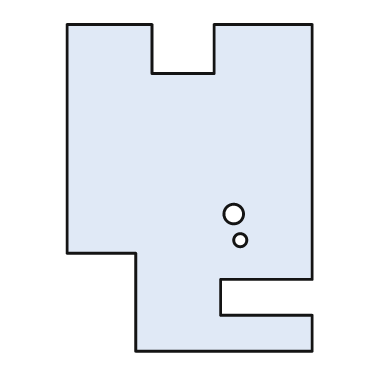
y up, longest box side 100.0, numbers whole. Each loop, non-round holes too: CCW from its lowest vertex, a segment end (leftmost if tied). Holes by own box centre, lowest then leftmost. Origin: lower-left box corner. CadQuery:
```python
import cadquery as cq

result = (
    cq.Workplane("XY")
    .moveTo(21.0, 0.0)
    .lineTo(75.0, 0.0)
    .lineTo(75.0, 11.0)
    .lineTo(47.0, 11.0)
    .lineTo(47.0, 22.0)
    .lineTo(75.0, 22.0)
    .lineTo(75.0, 100.0)
    .lineTo(45.0, 100.0)
    .lineTo(45.0, 85.0)
    .lineTo(26.0, 85.0)
    .lineTo(26.0, 100.0)
    .lineTo(0.0, 100.0)
    .lineTo(0.0, 30.0)
    .lineTo(21.0, 30.0)
    .close()
    .moveTo(53.0, 34.0)
    .circle(2.0)
    .moveTo(51.0, 42.0)
    .circle(3.0)
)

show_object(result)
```